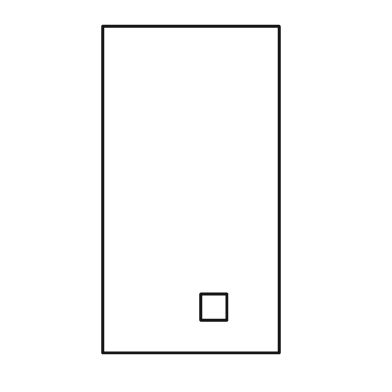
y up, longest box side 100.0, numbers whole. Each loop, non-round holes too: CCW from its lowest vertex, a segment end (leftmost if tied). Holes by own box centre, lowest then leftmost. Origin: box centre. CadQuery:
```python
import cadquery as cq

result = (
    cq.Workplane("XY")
    .moveTo(-27.0, -50.0)
    .lineTo(27.0, -50.0)
    .lineTo(27.0, 50.0)
    .lineTo(-27.0, 50.0)
    .close()
    .moveTo(3.0, -40.0)
    .lineTo(11.0, -40.0)
    .lineTo(11.0, -32.0)
    .lineTo(3.0, -32.0)
    .close()
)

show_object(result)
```